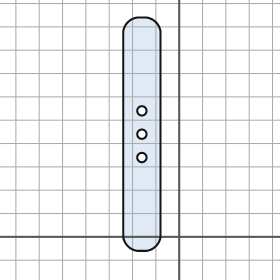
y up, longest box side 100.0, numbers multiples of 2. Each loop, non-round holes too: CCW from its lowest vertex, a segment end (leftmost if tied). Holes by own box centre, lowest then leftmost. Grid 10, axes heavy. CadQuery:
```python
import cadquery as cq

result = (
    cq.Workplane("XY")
    .moveTo(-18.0, -6.0)
    .lineTo(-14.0, -6.0)
    .threePointArc((-10.0, -4.0), (-8.0, 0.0))
    .lineTo(-8.0, 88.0)
    .threePointArc((-10.0, 92.0), (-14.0, 94.0))
    .lineTo(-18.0, 94.0)
    .threePointArc((-22.0, 92.0), (-24.0, 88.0))
    .lineTo(-24.0, 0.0)
    .threePointArc((-22.0, -4.0), (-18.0, -6.0))
    .close()
    .moveTo(-16.0, 34.0)
    .circle(2.0)
    .moveTo(-16.0, 44.0)
    .circle(2.0)
    .moveTo(-16.0, 54.0)
    .circle(2.0)
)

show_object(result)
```